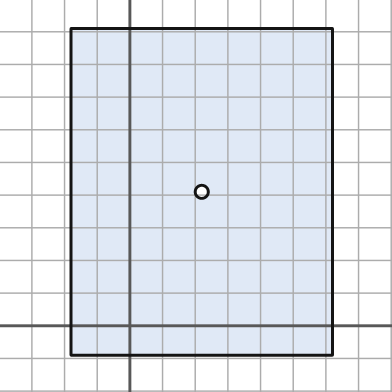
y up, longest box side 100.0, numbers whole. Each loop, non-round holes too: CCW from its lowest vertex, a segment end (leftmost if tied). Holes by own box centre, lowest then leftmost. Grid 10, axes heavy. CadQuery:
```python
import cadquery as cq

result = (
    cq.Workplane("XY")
    .moveTo(-18.0, -9.0)
    .lineTo(62.0, -9.0)
    .lineTo(62.0, 91.0)
    .lineTo(-18.0, 91.0)
    .close()
    .moveTo(22.0, 41.0)
    .circle(2.0)
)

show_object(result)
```